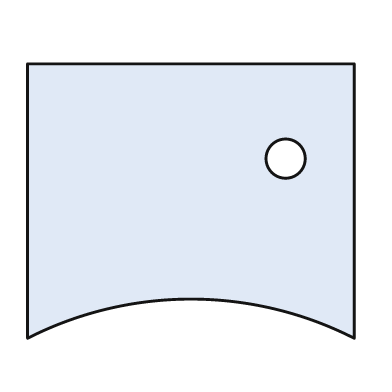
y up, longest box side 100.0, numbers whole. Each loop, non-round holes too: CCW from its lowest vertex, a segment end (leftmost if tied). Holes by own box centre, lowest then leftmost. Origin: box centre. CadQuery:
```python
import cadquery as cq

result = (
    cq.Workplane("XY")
    .moveTo(-50.0, -42.0)
    .threePointArc((0.0, -30.0), (50.0, -42.0))
    .lineTo(50.0, 42.0)
    .lineTo(-50.0, 42.0)
    .close()
    .moveTo(29.0, 13.0)
    .circle(6.0)
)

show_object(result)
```